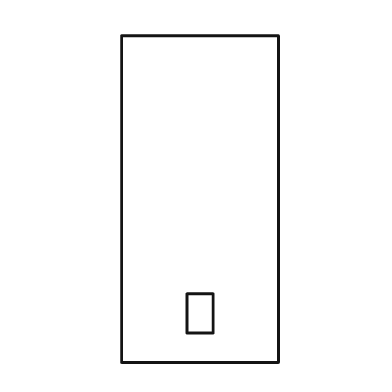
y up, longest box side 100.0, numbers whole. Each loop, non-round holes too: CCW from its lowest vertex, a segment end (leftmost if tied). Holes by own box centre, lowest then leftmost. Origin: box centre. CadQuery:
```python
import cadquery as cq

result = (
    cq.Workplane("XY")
    .moveTo(-24.0, -50.0)
    .lineTo(24.0, -50.0)
    .lineTo(24.0, 50.0)
    .lineTo(-24.0, 50.0)
    .close()
    .moveTo(-4.0, -41.0)
    .lineTo(4.0, -41.0)
    .lineTo(4.0, -29.0)
    .lineTo(-4.0, -29.0)
    .close()
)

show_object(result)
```